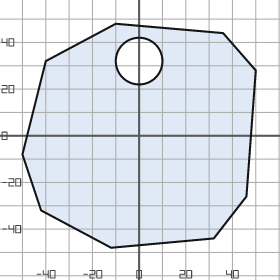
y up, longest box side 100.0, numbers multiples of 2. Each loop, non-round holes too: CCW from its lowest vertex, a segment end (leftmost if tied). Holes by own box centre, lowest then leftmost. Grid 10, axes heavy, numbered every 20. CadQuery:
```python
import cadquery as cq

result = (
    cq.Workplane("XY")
    .moveTo(-12.0, -48.0)
    .lineTo(32.0, -44.0)
    .lineTo(46.0, -26.0)
    .lineTo(50.0, 28.0)
    .lineTo(36.0, 44.0)
    .lineTo(-10.0, 48.0)
    .lineTo(-40.0, 32.0)
    .lineTo(-50.0, -8.0)
    .lineTo(-42.0, -32.0)
    .close()
    .moveTo(0.0, 32.0)
    .circle(10.0)
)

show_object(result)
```